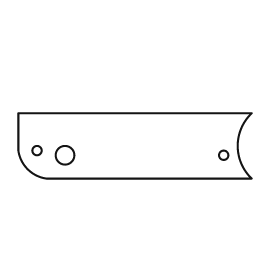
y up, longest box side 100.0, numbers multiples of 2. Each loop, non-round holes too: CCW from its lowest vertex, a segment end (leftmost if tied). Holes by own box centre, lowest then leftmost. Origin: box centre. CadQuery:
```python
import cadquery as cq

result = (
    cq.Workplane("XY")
    .moveTo(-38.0, -14.0)
    .lineTo(50.0, -14.0)
    .threePointArc((44.0, 0.0), (50.0, 14.0))
    .lineTo(-50.0, 14.0)
    .lineTo(-50.0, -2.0)
    .threePointArc((-46.0, -10.0), (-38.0, -14.0))
    .close()
    .moveTo(-30.0, -4.0)
    .circle(4.0)
    .moveTo(38.0, -4.0)
    .circle(2.0)
    .moveTo(-42.0, -2.0)
    .circle(2.0)
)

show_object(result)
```